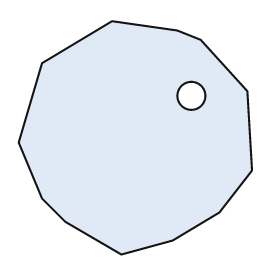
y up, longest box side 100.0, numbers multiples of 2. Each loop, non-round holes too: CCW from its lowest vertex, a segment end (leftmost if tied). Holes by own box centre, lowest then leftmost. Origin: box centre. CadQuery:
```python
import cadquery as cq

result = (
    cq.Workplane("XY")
    .moveTo(-6.0, -50.0)
    .lineTo(16.0, -44.0)
    .lineTo(36.0, -32.0)
    .lineTo(50.0, -14.0)
    .lineTo(48.0, 20.0)
    .lineTo(28.0, 42.0)
    .lineTo(18.0, 46.0)
    .lineTo(-10.0, 50.0)
    .lineTo(-40.0, 32.0)
    .lineTo(-50.0, -2.0)
    .lineTo(-40.0, -26.0)
    .lineTo(-30.0, -36.0)
    .close()
    .moveTo(24.0, 18.0)
    .circle(6.0)
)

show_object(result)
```